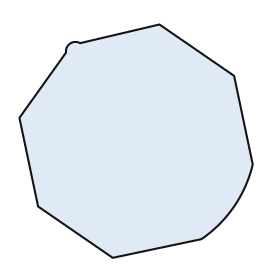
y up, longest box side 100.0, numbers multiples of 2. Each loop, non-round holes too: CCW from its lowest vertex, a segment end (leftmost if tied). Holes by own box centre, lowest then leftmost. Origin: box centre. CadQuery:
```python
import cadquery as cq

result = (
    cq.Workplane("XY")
    .moveTo(-10.0, -50.0)
    .lineTo(28.0, -42.0)
    .threePointArc((42.0, -28.0), (50.0, -10.0))
    .lineTo(42.0, 28.0)
    .lineTo(10.0, 50.0)
    .lineTo(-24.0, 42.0)
    .threePointArc((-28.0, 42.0), (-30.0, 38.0))
    .lineTo(-50.0, 10.0)
    .lineTo(-42.0, -28.0)
    .close()
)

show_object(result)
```